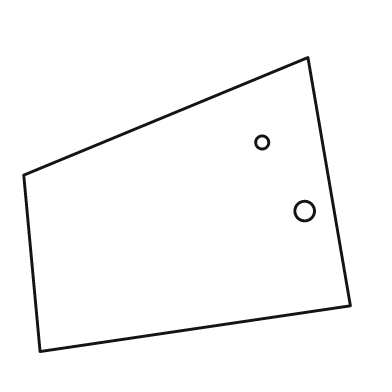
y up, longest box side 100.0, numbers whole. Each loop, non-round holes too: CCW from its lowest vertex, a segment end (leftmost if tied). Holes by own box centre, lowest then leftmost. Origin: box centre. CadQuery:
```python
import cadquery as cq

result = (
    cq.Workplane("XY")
    .moveTo(-45.0, -45.0)
    .lineTo(50.0, -31.0)
    .lineTo(37.0, 45.0)
    .lineTo(-50.0, 9.0)
    .close()
    .moveTo(36.0, -2.0)
    .circle(3.0)
    .moveTo(23.0, 19.0)
    .circle(2.0)
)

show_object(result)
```